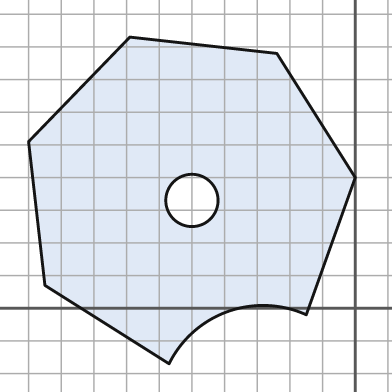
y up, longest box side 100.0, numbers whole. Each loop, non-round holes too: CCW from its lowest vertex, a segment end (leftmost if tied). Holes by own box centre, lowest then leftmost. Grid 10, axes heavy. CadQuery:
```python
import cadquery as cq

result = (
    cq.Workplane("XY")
    .moveTo(-57.0, -17.0)
    .threePointArc((-39.0, -1.0), (-15.0, -2.0))
    .lineTo(0.0, 40.0)
    .lineTo(-24.0, 78.0)
    .lineTo(-69.0, 83.0)
    .lineTo(-100.0, 51.0)
    .lineTo(-95.0, 7.0)
    .close()
    .moveTo(-50.0, 33.0)
    .circle(8.0)
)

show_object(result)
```